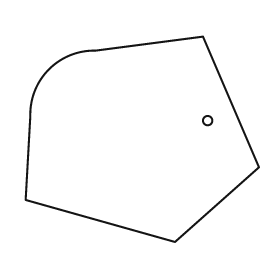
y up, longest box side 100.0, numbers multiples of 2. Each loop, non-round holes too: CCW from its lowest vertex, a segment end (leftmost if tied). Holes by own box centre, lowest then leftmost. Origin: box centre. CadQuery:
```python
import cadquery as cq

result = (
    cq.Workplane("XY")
    .moveTo(14.0, -44.0)
    .lineTo(50.0, -12.0)
    .lineTo(26.0, 44.0)
    .lineTo(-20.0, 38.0)
    .threePointArc((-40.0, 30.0), (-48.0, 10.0))
    .lineTo(-50.0, -26.0)
    .close()
    .moveTo(28.0, 8.0)
    .circle(2.0)
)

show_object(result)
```